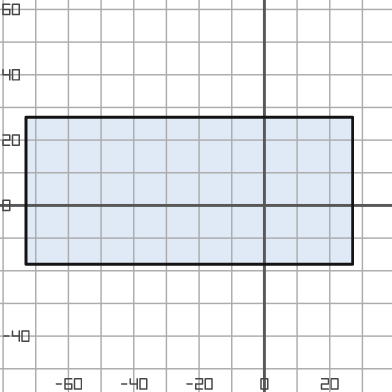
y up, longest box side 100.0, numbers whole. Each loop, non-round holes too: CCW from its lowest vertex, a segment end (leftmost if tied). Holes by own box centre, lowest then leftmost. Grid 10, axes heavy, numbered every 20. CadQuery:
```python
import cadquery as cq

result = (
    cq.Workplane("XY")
    .moveTo(-73.0, -18.0)
    .lineTo(27.0, -18.0)
    .lineTo(27.0, 27.0)
    .lineTo(-73.0, 27.0)
    .close()
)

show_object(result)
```